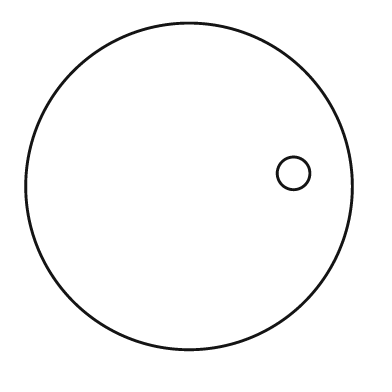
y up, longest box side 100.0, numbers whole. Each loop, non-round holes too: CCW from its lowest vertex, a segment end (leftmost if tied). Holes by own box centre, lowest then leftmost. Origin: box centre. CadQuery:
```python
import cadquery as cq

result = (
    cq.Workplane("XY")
    .moveTo(0.0, 0.0)
    .circle(50.0)
    .moveTo(32.0, 4.0)
    .circle(5.0)
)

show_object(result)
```